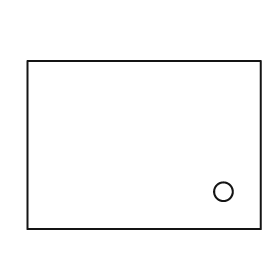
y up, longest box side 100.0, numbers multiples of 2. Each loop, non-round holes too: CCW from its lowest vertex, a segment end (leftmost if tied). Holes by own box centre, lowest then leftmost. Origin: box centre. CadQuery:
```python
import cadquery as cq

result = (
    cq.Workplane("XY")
    .moveTo(-50.0, -36.0)
    .lineTo(50.0, -36.0)
    .lineTo(50.0, 36.0)
    .lineTo(-50.0, 36.0)
    .close()
    .moveTo(34.0, -20.0)
    .circle(4.0)
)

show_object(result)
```